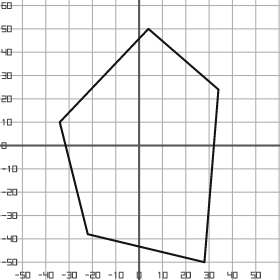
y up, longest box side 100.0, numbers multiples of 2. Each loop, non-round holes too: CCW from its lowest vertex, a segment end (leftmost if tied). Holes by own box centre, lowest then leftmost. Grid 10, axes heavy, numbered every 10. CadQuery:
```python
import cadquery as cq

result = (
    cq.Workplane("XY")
    .moveTo(28.0, -50.0)
    .lineTo(34.0, 24.0)
    .lineTo(4.0, 50.0)
    .lineTo(-34.0, 10.0)
    .lineTo(-22.0, -38.0)
    .close()
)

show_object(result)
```